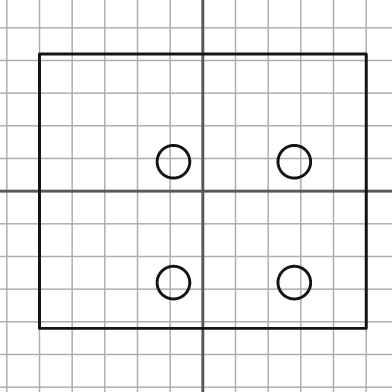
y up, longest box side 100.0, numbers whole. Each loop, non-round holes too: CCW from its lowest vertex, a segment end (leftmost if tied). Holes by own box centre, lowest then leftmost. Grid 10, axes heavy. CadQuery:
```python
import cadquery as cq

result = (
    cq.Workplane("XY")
    .moveTo(-50.0, -42.0)
    .lineTo(50.0, -42.0)
    .lineTo(50.0, 42.0)
    .lineTo(-50.0, 42.0)
    .close()
    .moveTo(-9.0, -28.0)
    .circle(5.0)
    .moveTo(28.0, -28.0)
    .circle(5.0)
    .moveTo(-9.0, 9.0)
    .circle(5.0)
    .moveTo(28.0, 9.0)
    .circle(5.0)
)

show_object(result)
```